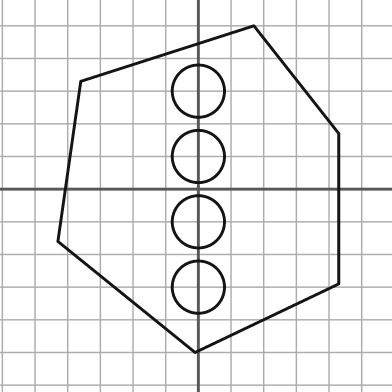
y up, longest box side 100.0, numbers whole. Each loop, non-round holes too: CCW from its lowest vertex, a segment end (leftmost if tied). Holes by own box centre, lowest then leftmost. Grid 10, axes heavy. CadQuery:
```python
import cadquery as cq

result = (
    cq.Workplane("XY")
    .moveTo(-1.0, -50.0)
    .lineTo(43.0, -29.0)
    .lineTo(43.0, 17.0)
    .lineTo(17.0, 50.0)
    .lineTo(-36.0, 33.0)
    .lineTo(-43.0, -16.0)
    .close()
    .moveTo(0.0, -30.0)
    .circle(8.0)
    .moveTo(0.0, -10.0)
    .circle(8.0)
    .moveTo(0.0, 10.0)
    .circle(8.0)
    .moveTo(0.0, 30.0)
    .circle(8.0)
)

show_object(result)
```